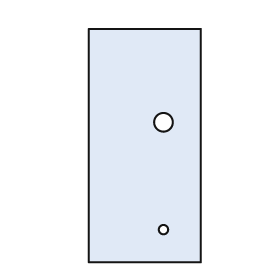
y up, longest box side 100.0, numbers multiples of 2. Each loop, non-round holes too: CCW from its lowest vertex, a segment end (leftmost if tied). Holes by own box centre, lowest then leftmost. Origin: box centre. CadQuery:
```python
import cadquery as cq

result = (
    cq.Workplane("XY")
    .moveTo(-24.0, -50.0)
    .lineTo(24.0, -50.0)
    .lineTo(24.0, 50.0)
    .lineTo(-24.0, 50.0)
    .close()
    .moveTo(8.0, -36.0)
    .circle(2.0)
    .moveTo(8.0, 10.0)
    .circle(4.0)
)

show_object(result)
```